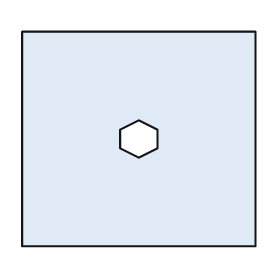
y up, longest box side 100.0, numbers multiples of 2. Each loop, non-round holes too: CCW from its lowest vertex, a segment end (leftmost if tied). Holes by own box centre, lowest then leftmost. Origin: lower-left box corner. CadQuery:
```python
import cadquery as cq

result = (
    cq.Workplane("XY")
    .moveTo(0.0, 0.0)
    .lineTo(100.0, 0.0)
    .lineTo(100.0, 92.0)
    .lineTo(0.0, 92.0)
    .close()
    .moveTo(50.0, 38.0)
    .lineTo(58.0, 42.0)
    .lineTo(58.0, 50.0)
    .lineTo(50.0, 54.0)
    .lineTo(42.0, 50.0)
    .lineTo(42.0, 42.0)
    .close()
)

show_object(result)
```